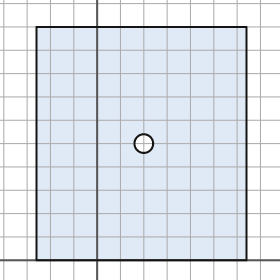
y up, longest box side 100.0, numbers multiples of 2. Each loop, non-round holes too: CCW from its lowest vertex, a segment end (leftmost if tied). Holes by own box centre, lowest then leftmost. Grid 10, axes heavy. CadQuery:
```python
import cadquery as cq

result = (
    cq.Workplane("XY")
    .moveTo(-26.0, 0.0)
    .lineTo(64.0, 0.0)
    .lineTo(64.0, 100.0)
    .lineTo(-26.0, 100.0)
    .close()
    .moveTo(20.0, 50.0)
    .circle(4.0)
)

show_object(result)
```